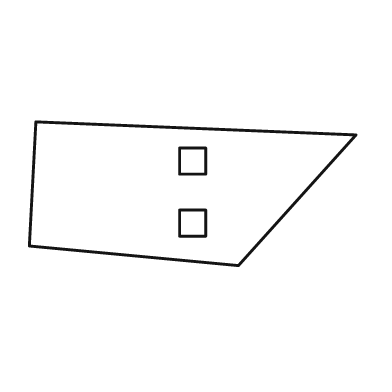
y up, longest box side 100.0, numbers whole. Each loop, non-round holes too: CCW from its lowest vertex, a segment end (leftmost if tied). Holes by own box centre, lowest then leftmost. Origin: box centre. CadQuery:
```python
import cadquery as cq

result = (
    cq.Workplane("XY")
    .moveTo(14.0, -22.0)
    .lineTo(50.0, 18.0)
    .lineTo(-48.0, 22.0)
    .lineTo(-50.0, -16.0)
    .close()
    .moveTo(-4.0, -13.0)
    .lineTo(4.0, -13.0)
    .lineTo(4.0, -5.0)
    .lineTo(-4.0, -5.0)
    .close()
    .moveTo(-4.0, 6.0)
    .lineTo(4.0, 6.0)
    .lineTo(4.0, 14.0)
    .lineTo(-4.0, 14.0)
    .close()
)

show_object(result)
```